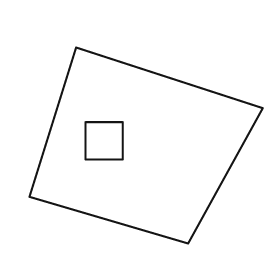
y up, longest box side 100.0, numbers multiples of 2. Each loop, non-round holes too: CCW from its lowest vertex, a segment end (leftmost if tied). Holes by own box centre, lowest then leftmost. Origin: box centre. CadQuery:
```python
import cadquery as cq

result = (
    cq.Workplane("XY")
    .moveTo(18.0, -42.0)
    .lineTo(50.0, 16.0)
    .lineTo(-30.0, 42.0)
    .lineTo(-50.0, -22.0)
    .close()
    .moveTo(-26.0, -6.0)
    .lineTo(-10.0, -6.0)
    .lineTo(-10.0, 10.0)
    .lineTo(-26.0, 10.0)
    .close()
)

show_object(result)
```